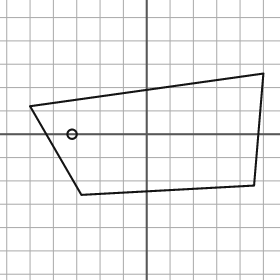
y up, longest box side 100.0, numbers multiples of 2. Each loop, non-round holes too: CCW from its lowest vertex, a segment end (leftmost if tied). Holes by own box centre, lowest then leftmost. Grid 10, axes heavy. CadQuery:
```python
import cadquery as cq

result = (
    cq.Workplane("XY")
    .moveTo(-28.0, -26.0)
    .lineTo(46.0, -22.0)
    .lineTo(50.0, 26.0)
    .lineTo(-50.0, 12.0)
    .close()
    .moveTo(-32.0, 0.0)
    .circle(2.0)
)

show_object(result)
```